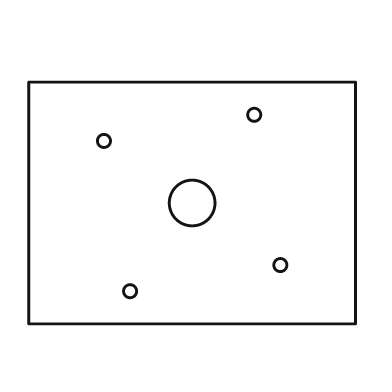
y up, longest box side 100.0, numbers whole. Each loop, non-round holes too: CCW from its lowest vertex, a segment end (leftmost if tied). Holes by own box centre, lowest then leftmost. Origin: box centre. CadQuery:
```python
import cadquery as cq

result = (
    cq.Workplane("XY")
    .moveTo(-50.0, -37.0)
    .lineTo(50.0, -37.0)
    .lineTo(50.0, 37.0)
    .lineTo(-50.0, 37.0)
    .close()
    .moveTo(-19.0, -27.0)
    .circle(2.0)
    .moveTo(27.0, -19.0)
    .circle(2.0)
    .moveTo(0.0, 0.0)
    .circle(7.0)
    .moveTo(-27.0, 19.0)
    .circle(2.0)
    .moveTo(19.0, 27.0)
    .circle(2.0)
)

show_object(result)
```